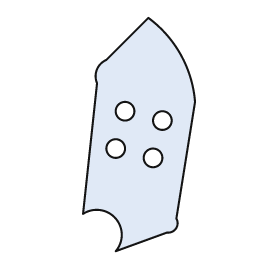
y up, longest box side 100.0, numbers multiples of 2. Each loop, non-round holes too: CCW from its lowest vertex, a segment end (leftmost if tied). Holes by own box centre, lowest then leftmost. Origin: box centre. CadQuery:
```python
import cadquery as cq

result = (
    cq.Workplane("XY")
    .moveTo(-10.0, -50.0)
    .lineTo(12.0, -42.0)
    .threePointArc((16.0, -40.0), (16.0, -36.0))
    .lineTo(24.0, 14.0)
    .threePointArc((18.0, 34.0), (4.0, 50.0))
    .lineTo(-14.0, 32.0)
    .threePointArc((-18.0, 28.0), (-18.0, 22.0))
    .lineTo(-24.0, -34.0)
    .threePointArc((-10.0, -36.0), (-10.0, -50.0))
    .close()
    .moveTo(6.0, -10.0)
    .circle(4.0)
    .moveTo(-10.0, -6.0)
    .circle(4.0)
    .moveTo(10.0, 6.0)
    .circle(4.0)
    .moveTo(-6.0, 10.0)
    .circle(4.0)
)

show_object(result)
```